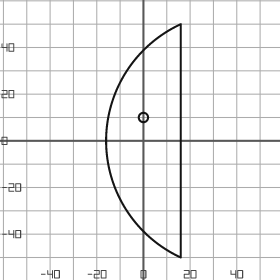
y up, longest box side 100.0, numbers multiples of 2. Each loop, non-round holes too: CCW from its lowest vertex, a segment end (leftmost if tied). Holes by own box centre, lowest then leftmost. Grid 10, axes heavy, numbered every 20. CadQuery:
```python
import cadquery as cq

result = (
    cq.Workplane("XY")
    .moveTo(16.0, -50.0)
    .lineTo(16.0, 50.0)
    .threePointArc((-16.0, 0.0), (16.0, -50.0))
    .close()
    .moveTo(0.0, 10.0)
    .circle(2.0)
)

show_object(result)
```